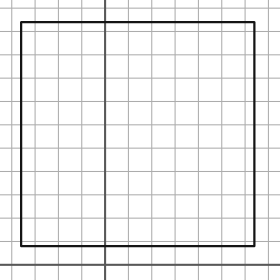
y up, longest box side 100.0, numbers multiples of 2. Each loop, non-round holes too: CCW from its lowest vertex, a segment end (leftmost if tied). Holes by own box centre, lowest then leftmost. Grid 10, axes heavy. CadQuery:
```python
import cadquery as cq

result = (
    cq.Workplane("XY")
    .moveTo(-36.0, 8.0)
    .lineTo(64.0, 8.0)
    .lineTo(64.0, 104.0)
    .lineTo(-36.0, 104.0)
    .close()
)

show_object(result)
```